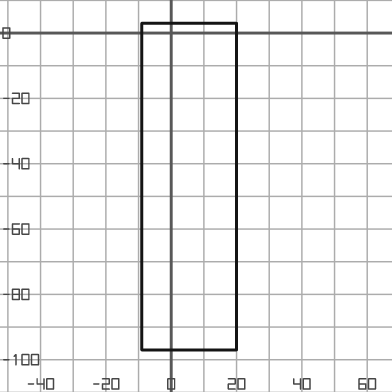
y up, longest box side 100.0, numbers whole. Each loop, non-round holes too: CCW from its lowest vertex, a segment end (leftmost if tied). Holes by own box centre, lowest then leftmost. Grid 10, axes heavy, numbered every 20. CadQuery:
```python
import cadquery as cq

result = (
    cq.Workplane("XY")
    .moveTo(-9.0, -97.0)
    .lineTo(20.0, -97.0)
    .lineTo(20.0, 3.0)
    .lineTo(-9.0, 3.0)
    .close()
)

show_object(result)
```